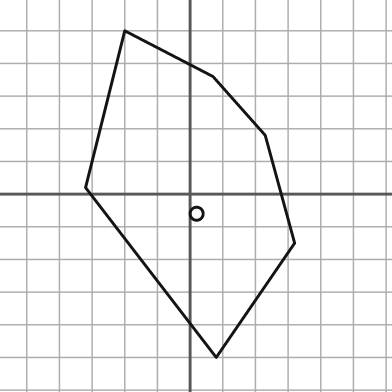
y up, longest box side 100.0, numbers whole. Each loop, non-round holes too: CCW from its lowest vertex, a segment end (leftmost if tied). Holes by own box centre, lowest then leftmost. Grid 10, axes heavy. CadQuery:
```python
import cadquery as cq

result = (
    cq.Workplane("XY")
    .moveTo(8.0, -50.0)
    .lineTo(32.0, -15.0)
    .lineTo(23.0, 18.0)
    .lineTo(7.0, 36.0)
    .lineTo(-20.0, 50.0)
    .lineTo(-32.0, 2.0)
    .close()
    .moveTo(2.0, -6.0)
    .circle(2.0)
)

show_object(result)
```